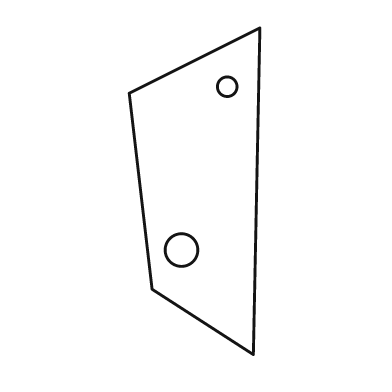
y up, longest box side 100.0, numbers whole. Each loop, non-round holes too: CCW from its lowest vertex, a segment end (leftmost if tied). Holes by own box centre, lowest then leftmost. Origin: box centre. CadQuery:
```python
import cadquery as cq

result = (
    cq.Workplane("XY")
    .moveTo(18.0, -50.0)
    .lineTo(20.0, 50.0)
    .lineTo(-20.0, 30.0)
    .lineTo(-13.0, -30.0)
    .close()
    .moveTo(-4.0, -18.0)
    .circle(5.0)
    .moveTo(10.0, 32.0)
    .circle(3.0)
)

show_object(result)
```